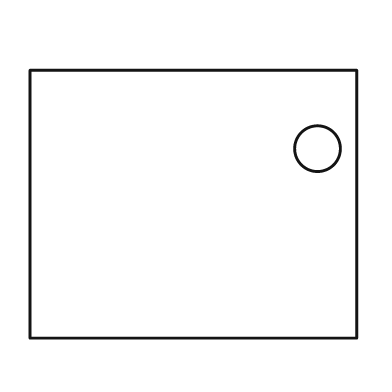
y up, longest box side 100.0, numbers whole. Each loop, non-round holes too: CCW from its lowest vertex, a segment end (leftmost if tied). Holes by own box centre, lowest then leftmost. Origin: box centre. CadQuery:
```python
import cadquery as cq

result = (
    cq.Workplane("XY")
    .moveTo(-50.0, -41.0)
    .lineTo(50.0, -41.0)
    .lineTo(50.0, 41.0)
    .lineTo(-50.0, 41.0)
    .close()
    .moveTo(38.0, 17.0)
    .circle(7.0)
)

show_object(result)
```